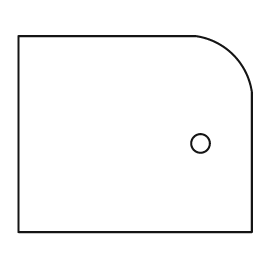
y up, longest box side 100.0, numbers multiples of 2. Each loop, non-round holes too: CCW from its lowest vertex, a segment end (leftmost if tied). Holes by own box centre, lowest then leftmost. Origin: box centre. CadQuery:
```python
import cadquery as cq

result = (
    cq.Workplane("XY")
    .moveTo(-50.0, -42.0)
    .lineTo(50.0, -42.0)
    .lineTo(50.0, 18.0)
    .threePointArc((42.0, 34.0), (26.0, 42.0))
    .lineTo(-50.0, 42.0)
    .close()
    .moveTo(28.0, -4.0)
    .circle(4.0)
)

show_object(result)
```